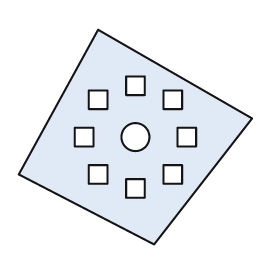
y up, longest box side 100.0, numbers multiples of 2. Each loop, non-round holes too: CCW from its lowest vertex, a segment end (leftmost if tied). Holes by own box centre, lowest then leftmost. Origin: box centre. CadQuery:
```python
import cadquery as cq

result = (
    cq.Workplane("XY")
    .moveTo(8.0, -46.0)
    .lineTo(50.0, 8.0)
    .lineTo(-16.0, 46.0)
    .lineTo(-50.0, -16.0)
    .close()
    .moveTo(-4.0, -26.0)
    .lineTo(4.0, -26.0)
    .lineTo(4.0, -18.0)
    .lineTo(-4.0, -18.0)
    .close()
    .moveTo(-20.0, -20.0)
    .lineTo(-12.0, -20.0)
    .lineTo(-12.0, -12.0)
    .lineTo(-20.0, -12.0)
    .close()
    .moveTo(12.0, -20.0)
    .lineTo(20.0, -20.0)
    .lineTo(20.0, -12.0)
    .lineTo(12.0, -12.0)
    .close()
    .moveTo(-26.0, -4.0)
    .lineTo(-18.0, -4.0)
    .lineTo(-18.0, 4.0)
    .lineTo(-26.0, 4.0)
    .close()
    .moveTo(0.0, 0.0)
    .circle(6.0)
    .moveTo(18.0, -4.0)
    .lineTo(26.0, -4.0)
    .lineTo(26.0, 4.0)
    .lineTo(18.0, 4.0)
    .close()
    .moveTo(-20.0, 12.0)
    .lineTo(-12.0, 12.0)
    .lineTo(-12.0, 20.0)
    .lineTo(-20.0, 20.0)
    .close()
    .moveTo(12.0, 12.0)
    .lineTo(20.0, 12.0)
    .lineTo(20.0, 20.0)
    .lineTo(12.0, 20.0)
    .close()
    .moveTo(-4.0, 18.0)
    .lineTo(4.0, 18.0)
    .lineTo(4.0, 26.0)
    .lineTo(-4.0, 26.0)
    .close()
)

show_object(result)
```